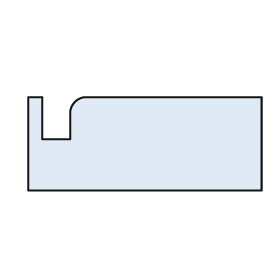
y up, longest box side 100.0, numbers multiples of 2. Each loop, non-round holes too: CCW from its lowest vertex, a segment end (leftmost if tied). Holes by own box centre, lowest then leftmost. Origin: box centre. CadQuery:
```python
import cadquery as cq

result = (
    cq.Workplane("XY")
    .moveTo(-50.0, -20.0)
    .lineTo(50.0, -20.0)
    .lineTo(50.0, 20.0)
    .lineTo(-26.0, 20.0)
    .threePointArc((-30.0, 18.0), (-32.0, 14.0))
    .lineTo(-32.0, 2.0)
    .lineTo(-44.0, 2.0)
    .lineTo(-44.0, 20.0)
    .lineTo(-50.0, 20.0)
    .close()
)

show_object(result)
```